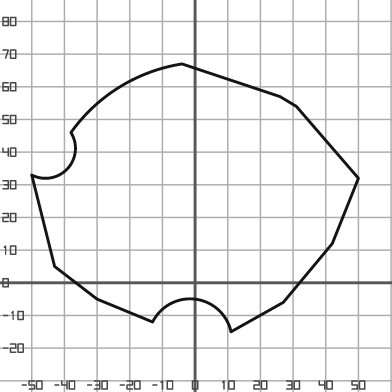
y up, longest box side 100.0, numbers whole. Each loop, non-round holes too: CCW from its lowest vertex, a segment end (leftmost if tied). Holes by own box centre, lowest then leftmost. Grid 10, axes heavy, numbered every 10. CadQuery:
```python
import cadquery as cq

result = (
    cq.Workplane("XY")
    .moveTo(11.0, -15.0)
    .lineTo(27.0, -6.0)
    .lineTo(42.0, 12.0)
    .lineTo(50.0, 32.0)
    .lineTo(31.0, 54.0)
    .lineTo(26.0, 57.0)
    .lineTo(-4.0, 67.0)
    .threePointArc((-23.0, 60.0), (-38.0, 46.0))
    .threePointArc((-39.0, 35.0), (-50.0, 33.0))
    .lineTo(-43.0, 5.0)
    .lineTo(-30.0, -5.0)
    .lineTo(-13.0, -12.0)
    .threePointArc((0.0, -5.0), (11.0, -15.0))
    .close()
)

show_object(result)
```